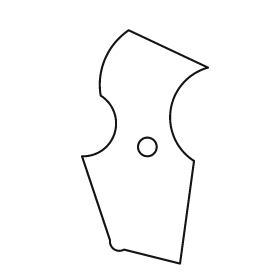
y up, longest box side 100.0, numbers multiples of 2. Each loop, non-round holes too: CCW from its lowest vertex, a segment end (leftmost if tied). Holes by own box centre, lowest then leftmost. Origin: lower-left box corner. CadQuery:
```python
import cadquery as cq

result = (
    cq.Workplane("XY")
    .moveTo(42.0, 0.0)
    .lineTo(48.0, 44.0)
    .threePointArc((38.0, 66.0), (54.0, 84.0))
    .lineTo(20.0, 100.0)
    .threePointArc((10.0, 88.0), (8.0, 72.0))
    .threePointArc((14.0, 56.0), (0.0, 46.0))
    .lineTo(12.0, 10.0)
    .threePointArc((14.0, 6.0), (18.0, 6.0))
    .close()
    .moveTo(28.0, 50.0)
    .circle(4.0)
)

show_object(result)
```